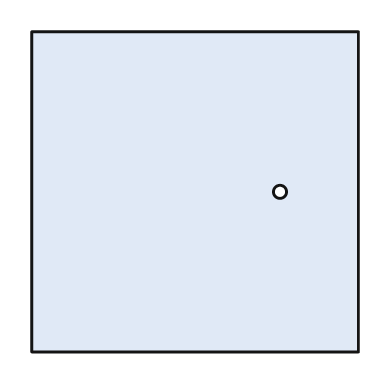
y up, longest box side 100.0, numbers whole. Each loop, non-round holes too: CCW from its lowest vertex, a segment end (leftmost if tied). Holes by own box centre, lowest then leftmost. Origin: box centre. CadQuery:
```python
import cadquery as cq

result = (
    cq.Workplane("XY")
    .moveTo(-50.0, -49.0)
    .lineTo(50.0, -49.0)
    .lineTo(50.0, 49.0)
    .lineTo(-50.0, 49.0)
    .close()
    .moveTo(26.0, 0.0)
    .circle(2.0)
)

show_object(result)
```